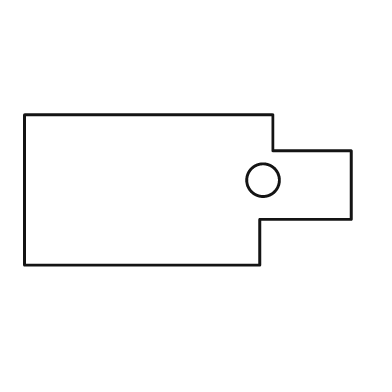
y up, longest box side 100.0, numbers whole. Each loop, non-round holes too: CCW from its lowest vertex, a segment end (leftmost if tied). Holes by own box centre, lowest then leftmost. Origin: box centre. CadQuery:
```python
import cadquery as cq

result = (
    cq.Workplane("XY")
    .moveTo(-50.0, -23.0)
    .lineTo(22.0, -23.0)
    .lineTo(22.0, -9.0)
    .lineTo(50.0, -9.0)
    .lineTo(50.0, 12.0)
    .lineTo(26.0, 12.0)
    .lineTo(26.0, 23.0)
    .lineTo(-50.0, 23.0)
    .close()
    .moveTo(23.0, 3.0)
    .circle(5.0)
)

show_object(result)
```